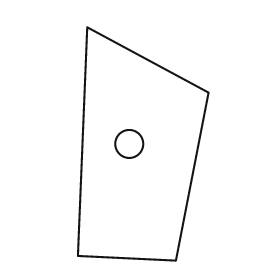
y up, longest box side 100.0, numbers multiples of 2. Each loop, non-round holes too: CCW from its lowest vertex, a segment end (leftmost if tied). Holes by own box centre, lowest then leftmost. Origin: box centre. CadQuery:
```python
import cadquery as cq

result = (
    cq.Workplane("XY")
    .moveTo(14.0, -50.0)
    .lineTo(28.0, 22.0)
    .lineTo(-24.0, 50.0)
    .lineTo(-28.0, -48.0)
    .close()
    .moveTo(-6.0, 0.0)
    .circle(6.0)
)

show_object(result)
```